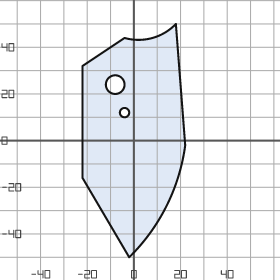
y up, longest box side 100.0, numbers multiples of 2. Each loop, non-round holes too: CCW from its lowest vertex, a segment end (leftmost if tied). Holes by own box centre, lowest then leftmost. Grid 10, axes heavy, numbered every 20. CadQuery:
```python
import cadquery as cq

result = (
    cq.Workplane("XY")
    .moveTo(-2.0, -50.0)
    .threePointArc((14.0, -28.0), (22.0, -2.0))
    .lineTo(18.0, 50.0)
    .threePointArc((8.0, 44.0), (-4.0, 44.0))
    .lineTo(-22.0, 32.0)
    .lineTo(-22.0, -16.0)
    .close()
    .moveTo(-4.0, 12.0)
    .circle(2.0)
    .moveTo(-8.0, 24.0)
    .circle(4.0)
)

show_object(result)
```